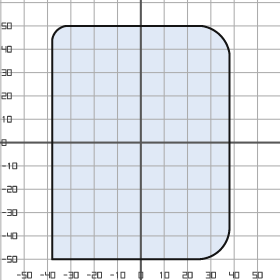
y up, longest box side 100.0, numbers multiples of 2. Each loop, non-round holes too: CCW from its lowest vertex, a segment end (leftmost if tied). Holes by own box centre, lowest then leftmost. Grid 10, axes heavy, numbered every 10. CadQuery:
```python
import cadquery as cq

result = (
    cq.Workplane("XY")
    .moveTo(-38.0, -50.0)
    .lineTo(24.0, -50.0)
    .threePointArc((34.0, -46.0), (38.0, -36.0))
    .lineTo(38.0, 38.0)
    .threePointArc((34.0, 46.0), (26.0, 50.0))
    .lineTo(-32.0, 50.0)
    .threePointArc((-36.0, 48.0), (-38.0, 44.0))
    .close()
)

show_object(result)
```